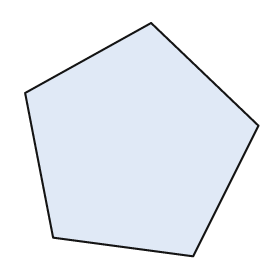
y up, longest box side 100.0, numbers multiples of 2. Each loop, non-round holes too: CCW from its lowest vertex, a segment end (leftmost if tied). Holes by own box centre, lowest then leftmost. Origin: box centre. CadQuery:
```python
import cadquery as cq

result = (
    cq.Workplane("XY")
    .moveTo(22.0, -50.0)
    .lineTo(50.0, 6.0)
    .lineTo(4.0, 50.0)
    .lineTo(-50.0, 20.0)
    .lineTo(-38.0, -42.0)
    .close()
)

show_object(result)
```